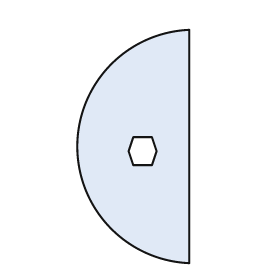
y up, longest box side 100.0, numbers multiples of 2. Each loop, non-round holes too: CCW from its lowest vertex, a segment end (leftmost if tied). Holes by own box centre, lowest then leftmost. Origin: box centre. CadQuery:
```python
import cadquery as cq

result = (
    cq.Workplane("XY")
    .moveTo(24.0, -50.0)
    .lineTo(24.0, 50.0)
    .threePointArc((-24.0, 0.0), (24.0, -50.0))
    .close()
    .moveTo(0.0, -8.0)
    .lineTo(8.0, -8.0)
    .lineTo(10.0, -2.0)
    .lineTo(8.0, 4.0)
    .lineTo(0.0, 4.0)
    .lineTo(-2.0, -2.0)
    .close()
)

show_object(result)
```